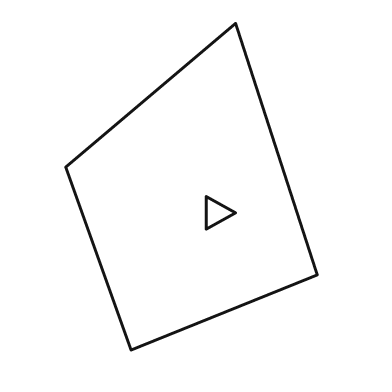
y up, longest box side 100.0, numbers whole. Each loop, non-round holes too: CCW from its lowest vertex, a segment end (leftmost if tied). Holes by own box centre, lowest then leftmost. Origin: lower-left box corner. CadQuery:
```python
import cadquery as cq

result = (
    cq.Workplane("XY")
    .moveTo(20.0, 0.0)
    .lineTo(77.0, 23.0)
    .lineTo(52.0, 100.0)
    .lineTo(0.0, 56.0)
    .close()
    .moveTo(43.0, 37.0)
    .lineTo(52.0, 42.0)
    .lineTo(43.0, 47.0)
    .close()
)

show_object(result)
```